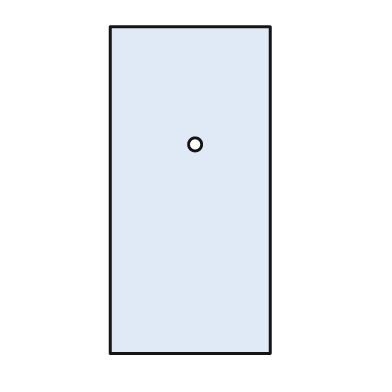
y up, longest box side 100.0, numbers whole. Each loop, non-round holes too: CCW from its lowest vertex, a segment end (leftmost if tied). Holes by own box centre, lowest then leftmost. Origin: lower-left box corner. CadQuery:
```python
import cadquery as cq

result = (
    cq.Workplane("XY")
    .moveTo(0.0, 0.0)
    .lineTo(49.0, 0.0)
    .lineTo(49.0, 100.0)
    .lineTo(0.0, 100.0)
    .close()
    .moveTo(26.0, 64.0)
    .circle(2.0)
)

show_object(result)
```